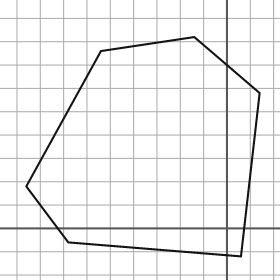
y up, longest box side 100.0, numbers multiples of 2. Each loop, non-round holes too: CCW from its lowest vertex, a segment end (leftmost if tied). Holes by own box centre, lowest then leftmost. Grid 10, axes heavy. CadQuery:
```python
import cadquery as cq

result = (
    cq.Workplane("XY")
    .moveTo(6.0, -12.0)
    .lineTo(14.0, 58.0)
    .lineTo(-14.0, 82.0)
    .lineTo(-54.0, 76.0)
    .lineTo(-86.0, 18.0)
    .lineTo(-68.0, -6.0)
    .close()
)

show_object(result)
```